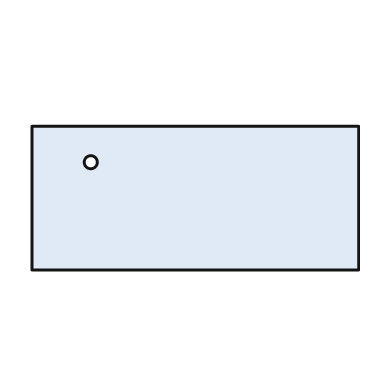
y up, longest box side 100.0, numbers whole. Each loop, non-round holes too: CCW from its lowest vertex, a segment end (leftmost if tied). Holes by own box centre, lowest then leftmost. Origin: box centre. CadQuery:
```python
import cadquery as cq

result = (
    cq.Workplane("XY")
    .moveTo(-50.0, -22.0)
    .lineTo(50.0, -22.0)
    .lineTo(50.0, 22.0)
    .lineTo(-50.0, 22.0)
    .close()
    .moveTo(-32.0, 11.0)
    .circle(2.0)
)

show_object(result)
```